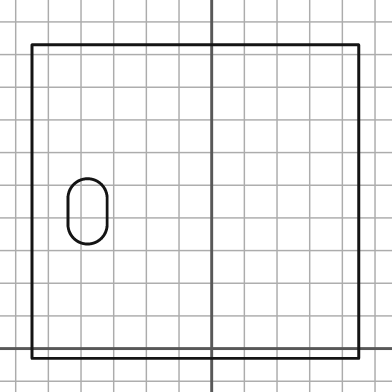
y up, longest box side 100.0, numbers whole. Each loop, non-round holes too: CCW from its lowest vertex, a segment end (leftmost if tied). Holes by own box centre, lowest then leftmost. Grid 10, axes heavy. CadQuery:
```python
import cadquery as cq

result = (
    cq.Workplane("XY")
    .moveTo(-55.0, -3.0)
    .lineTo(45.0, -3.0)
    .lineTo(45.0, 93.0)
    .lineTo(-55.0, 93.0)
    .close()
    .moveTo(-44.0, 38.0)
    .threePointArc((-38.0, 32.0), (-32.0, 38.0))
    .lineTo(-32.0, 46.0)
    .threePointArc((-38.0, 52.0), (-44.0, 46.0))
    .close()
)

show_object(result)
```